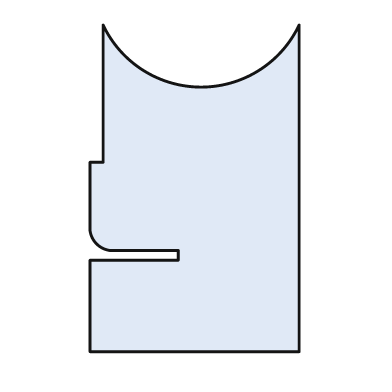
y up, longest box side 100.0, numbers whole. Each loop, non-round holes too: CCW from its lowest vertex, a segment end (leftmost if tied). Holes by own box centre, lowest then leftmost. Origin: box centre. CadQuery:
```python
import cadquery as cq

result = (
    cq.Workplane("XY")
    .moveTo(-32.0, -50.0)
    .lineTo(32.0, -50.0)
    .lineTo(32.0, 50.0)
    .threePointArc((2.0, 31.0), (-28.0, 50.0))
    .lineTo(-28.0, 8.0)
    .lineTo(-32.0, 8.0)
    .lineTo(-32.0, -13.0)
    .threePointArc((-30.0, -17.0), (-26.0, -19.0))
    .lineTo(-5.0, -19.0)
    .lineTo(-5.0, -22.0)
    .lineTo(-32.0, -22.0)
    .close()
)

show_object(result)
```